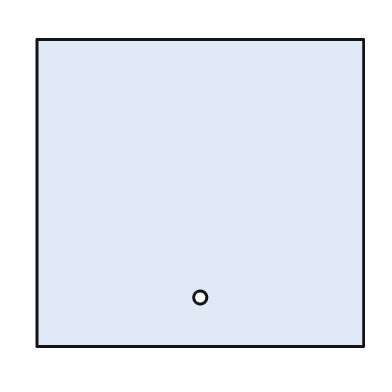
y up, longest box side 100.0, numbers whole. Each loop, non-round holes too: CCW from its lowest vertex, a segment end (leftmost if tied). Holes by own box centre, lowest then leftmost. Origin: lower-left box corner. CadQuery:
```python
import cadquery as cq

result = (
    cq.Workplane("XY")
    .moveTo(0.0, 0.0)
    .lineTo(100.0, 0.0)
    .lineTo(100.0, 94.0)
    .lineTo(0.0, 94.0)
    .close()
    .moveTo(50.0, 15.0)
    .circle(2.0)
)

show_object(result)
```